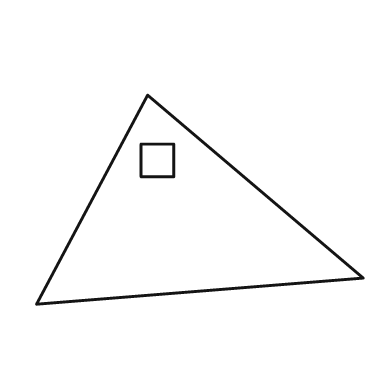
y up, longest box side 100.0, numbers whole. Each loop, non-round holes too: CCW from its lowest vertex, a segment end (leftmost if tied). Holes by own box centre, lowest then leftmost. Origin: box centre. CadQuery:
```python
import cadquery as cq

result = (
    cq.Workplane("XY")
    .moveTo(-50.0, -32.0)
    .lineTo(50.0, -24.0)
    .lineTo(-16.0, 32.0)
    .close()
    .moveTo(-18.0, 7.0)
    .lineTo(-8.0, 7.0)
    .lineTo(-8.0, 17.0)
    .lineTo(-18.0, 17.0)
    .close()
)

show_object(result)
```